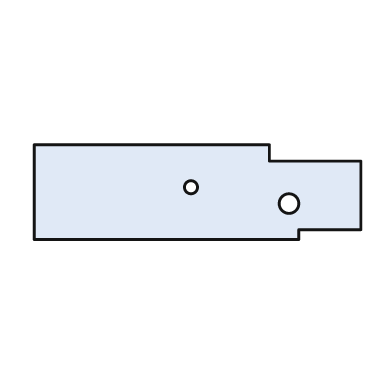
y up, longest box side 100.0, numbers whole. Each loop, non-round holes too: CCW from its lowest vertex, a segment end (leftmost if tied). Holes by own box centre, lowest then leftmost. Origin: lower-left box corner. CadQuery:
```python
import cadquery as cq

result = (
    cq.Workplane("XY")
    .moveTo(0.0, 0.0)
    .lineTo(81.0, 0.0)
    .lineTo(81.0, 3.0)
    .lineTo(100.0, 3.0)
    .lineTo(100.0, 24.0)
    .lineTo(72.0, 24.0)
    .lineTo(72.0, 29.0)
    .lineTo(0.0, 29.0)
    .close()
    .moveTo(78.0, 11.0)
    .circle(3.0)
    .moveTo(48.0, 16.0)
    .circle(2.0)
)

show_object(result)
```